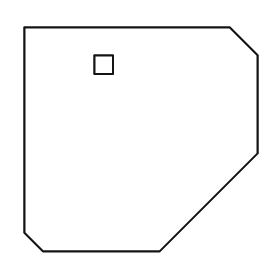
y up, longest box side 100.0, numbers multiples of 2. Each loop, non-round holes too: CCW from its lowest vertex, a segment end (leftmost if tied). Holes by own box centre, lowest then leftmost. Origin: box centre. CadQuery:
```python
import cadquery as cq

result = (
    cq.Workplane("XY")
    .moveTo(-42.0, -48.0)
    .lineTo(8.0, -48.0)
    .lineTo(50.0, -6.0)
    .lineTo(50.0, 36.0)
    .lineTo(38.0, 48.0)
    .lineTo(-50.0, 48.0)
    .lineTo(-50.0, -40.0)
    .close()
    .moveTo(-20.0, 28.0)
    .lineTo(-12.0, 28.0)
    .lineTo(-12.0, 36.0)
    .lineTo(-20.0, 36.0)
    .close()
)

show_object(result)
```